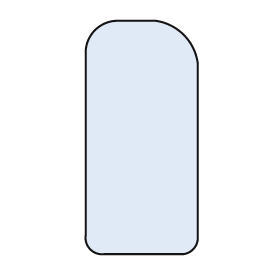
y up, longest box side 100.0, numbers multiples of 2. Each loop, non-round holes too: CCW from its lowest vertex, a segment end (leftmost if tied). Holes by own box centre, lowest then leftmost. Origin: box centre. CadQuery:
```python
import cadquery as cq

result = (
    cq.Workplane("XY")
    .moveTo(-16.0, -50.0)
    .lineTo(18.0, -50.0)
    .threePointArc((22.0, -48.0), (24.0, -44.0))
    .lineTo(24.0, 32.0)
    .threePointArc((18.0, 44.0), (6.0, 50.0))
    .lineTo(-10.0, 50.0)
    .threePointArc((-20.0, 46.0), (-24.0, 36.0))
    .lineTo(-24.0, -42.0)
    .threePointArc((-22.0, -48.0), (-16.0, -50.0))
    .close()
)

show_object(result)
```